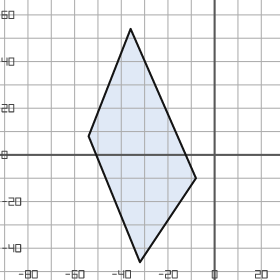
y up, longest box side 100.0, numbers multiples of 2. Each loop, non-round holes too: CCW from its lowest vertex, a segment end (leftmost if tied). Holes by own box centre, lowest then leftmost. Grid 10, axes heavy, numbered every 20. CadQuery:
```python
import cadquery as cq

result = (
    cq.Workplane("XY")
    .moveTo(-32.0, -46.0)
    .lineTo(-8.0, -10.0)
    .lineTo(-36.0, 54.0)
    .lineTo(-54.0, 8.0)
    .close()
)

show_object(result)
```